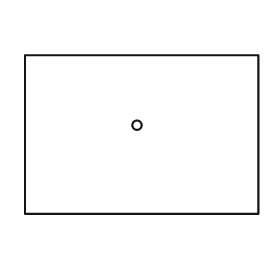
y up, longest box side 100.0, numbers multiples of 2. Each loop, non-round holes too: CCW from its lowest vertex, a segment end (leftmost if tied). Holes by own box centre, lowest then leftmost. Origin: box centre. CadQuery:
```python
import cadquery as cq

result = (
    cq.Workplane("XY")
    .moveTo(-50.0, -34.0)
    .lineTo(50.0, -34.0)
    .lineTo(50.0, 34.0)
    .lineTo(-50.0, 34.0)
    .close()
    .moveTo(-2.0, 4.0)
    .circle(2.0)
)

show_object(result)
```